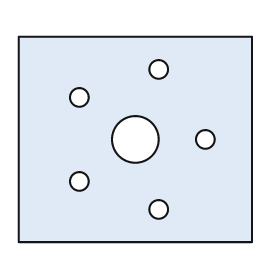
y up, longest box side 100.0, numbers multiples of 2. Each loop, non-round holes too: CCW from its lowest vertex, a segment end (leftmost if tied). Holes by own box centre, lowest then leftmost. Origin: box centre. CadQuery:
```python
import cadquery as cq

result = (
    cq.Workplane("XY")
    .moveTo(-50.0, -44.0)
    .lineTo(50.0, -44.0)
    .lineTo(50.0, 44.0)
    .lineTo(-50.0, 44.0)
    .close()
    .moveTo(10.0, -30.0)
    .circle(4.0)
    .moveTo(-24.0, -18.0)
    .circle(4.0)
    .moveTo(0.0, 0.0)
    .circle(10.0)
    .moveTo(30.0, 0.0)
    .circle(4.0)
    .moveTo(-24.0, 18.0)
    .circle(4.0)
    .moveTo(10.0, 30.0)
    .circle(4.0)
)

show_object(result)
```